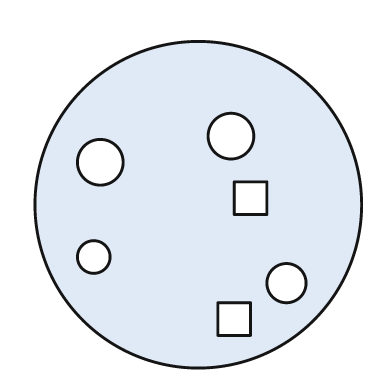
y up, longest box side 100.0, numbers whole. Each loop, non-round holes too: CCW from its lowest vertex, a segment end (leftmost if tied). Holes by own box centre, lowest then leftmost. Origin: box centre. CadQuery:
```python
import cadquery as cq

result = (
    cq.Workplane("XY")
    .moveTo(0.0, 0.0)
    .circle(50.0)
    .moveTo(6.0, -40.0)
    .lineTo(16.0, -40.0)
    .lineTo(16.0, -30.0)
    .lineTo(6.0, -30.0)
    .close()
    .moveTo(27.0, -24.0)
    .circle(6.0)
    .moveTo(-32.0, -16.0)
    .circle(5.0)
    .moveTo(11.0, -3.0)
    .lineTo(21.0, -3.0)
    .lineTo(21.0, 7.0)
    .lineTo(11.0, 7.0)
    .close()
    .moveTo(-30.0, 13.0)
    .circle(7.0)
    .moveTo(10.0, 21.0)
    .circle(7.0)
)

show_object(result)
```